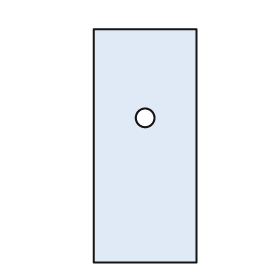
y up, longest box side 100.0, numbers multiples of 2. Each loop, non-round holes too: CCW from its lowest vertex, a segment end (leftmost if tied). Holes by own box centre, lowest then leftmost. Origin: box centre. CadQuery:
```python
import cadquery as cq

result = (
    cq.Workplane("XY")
    .moveTo(-22.0, -50.0)
    .lineTo(22.0, -50.0)
    .lineTo(22.0, 50.0)
    .lineTo(-22.0, 50.0)
    .close()
    .moveTo(0.0, 12.0)
    .circle(4.0)
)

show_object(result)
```